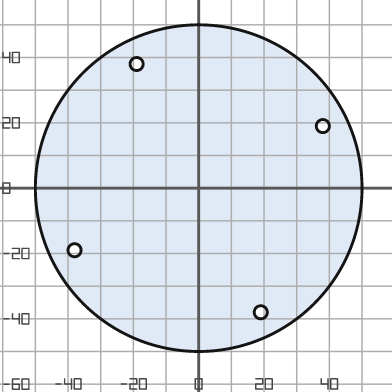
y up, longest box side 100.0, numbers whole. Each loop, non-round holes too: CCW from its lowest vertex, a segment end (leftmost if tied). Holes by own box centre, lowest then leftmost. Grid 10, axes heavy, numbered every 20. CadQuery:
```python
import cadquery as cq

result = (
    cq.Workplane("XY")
    .moveTo(0.0, 0.0)
    .circle(50.0)
    .moveTo(19.0, -38.0)
    .circle(2.0)
    .moveTo(-38.0, -19.0)
    .circle(2.0)
    .moveTo(38.0, 19.0)
    .circle(2.0)
    .moveTo(-19.0, 38.0)
    .circle(2.0)
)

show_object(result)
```